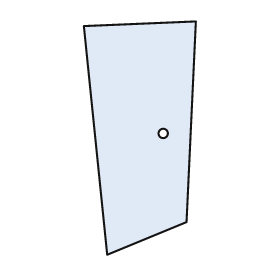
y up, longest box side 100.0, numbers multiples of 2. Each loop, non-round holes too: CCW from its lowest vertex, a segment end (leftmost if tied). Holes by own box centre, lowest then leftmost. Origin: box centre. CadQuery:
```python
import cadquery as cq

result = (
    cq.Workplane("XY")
    .moveTo(-14.0, -50.0)
    .lineTo(20.0, -36.0)
    .lineTo(24.0, 50.0)
    .lineTo(-24.0, 48.0)
    .close()
    .moveTo(10.0, 2.0)
    .circle(2.0)
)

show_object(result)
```